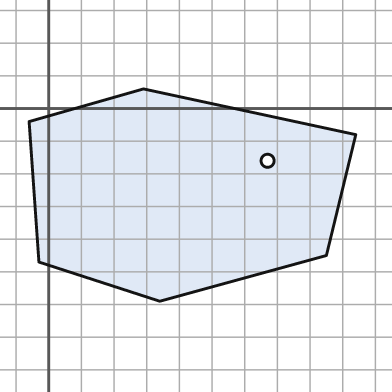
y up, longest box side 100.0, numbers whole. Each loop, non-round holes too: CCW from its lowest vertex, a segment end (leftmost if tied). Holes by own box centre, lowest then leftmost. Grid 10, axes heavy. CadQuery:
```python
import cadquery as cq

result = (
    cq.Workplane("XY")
    .moveTo(34.0, -59.0)
    .lineTo(85.0, -45.0)
    .lineTo(94.0, -8.0)
    .lineTo(29.0, 6.0)
    .lineTo(-6.0, -4.0)
    .lineTo(-3.0, -47.0)
    .close()
    .moveTo(67.0, -16.0)
    .circle(2.0)
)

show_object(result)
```